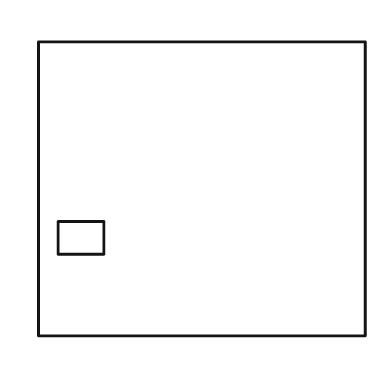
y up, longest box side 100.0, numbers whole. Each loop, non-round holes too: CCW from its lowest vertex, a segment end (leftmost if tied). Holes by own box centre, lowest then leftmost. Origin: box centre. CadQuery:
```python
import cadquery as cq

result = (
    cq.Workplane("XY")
    .moveTo(-50.0, -45.0)
    .lineTo(50.0, -45.0)
    .lineTo(50.0, 45.0)
    .lineTo(-50.0, 45.0)
    .close()
    .moveTo(-44.0, -20.0)
    .lineTo(-30.0, -20.0)
    .lineTo(-30.0, -10.0)
    .lineTo(-44.0, -10.0)
    .close()
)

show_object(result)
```